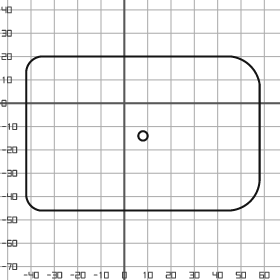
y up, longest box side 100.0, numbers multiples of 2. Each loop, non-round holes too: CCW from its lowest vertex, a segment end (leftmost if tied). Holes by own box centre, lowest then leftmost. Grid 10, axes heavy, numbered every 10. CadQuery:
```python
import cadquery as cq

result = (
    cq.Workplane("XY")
    .moveTo(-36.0, -46.0)
    .lineTo(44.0, -46.0)
    .threePointArc((54.0, -42.0), (58.0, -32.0))
    .lineTo(58.0, 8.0)
    .threePointArc((54.0, 16.0), (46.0, 20.0))
    .lineTo(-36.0, 20.0)
    .threePointArc((-40.0, 18.0), (-42.0, 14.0))
    .lineTo(-42.0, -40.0)
    .threePointArc((-40.0, -44.0), (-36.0, -46.0))
    .close()
    .moveTo(8.0, -14.0)
    .circle(2.0)
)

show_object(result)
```